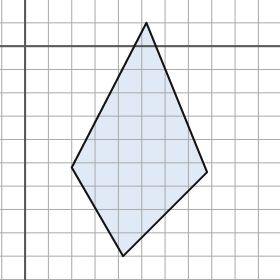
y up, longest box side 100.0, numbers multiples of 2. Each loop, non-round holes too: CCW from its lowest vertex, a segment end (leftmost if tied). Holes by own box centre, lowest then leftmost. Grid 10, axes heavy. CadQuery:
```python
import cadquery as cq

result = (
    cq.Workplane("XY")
    .moveTo(42.0, -90.0)
    .lineTo(78.0, -54.0)
    .lineTo(52.0, 10.0)
    .lineTo(20.0, -52.0)
    .close()
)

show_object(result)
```